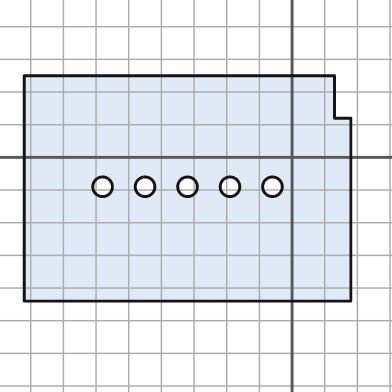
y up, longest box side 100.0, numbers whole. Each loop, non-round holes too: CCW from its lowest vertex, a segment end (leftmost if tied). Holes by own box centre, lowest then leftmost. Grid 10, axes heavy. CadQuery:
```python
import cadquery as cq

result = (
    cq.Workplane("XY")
    .moveTo(-82.0, -44.0)
    .lineTo(18.0, -44.0)
    .lineTo(18.0, 12.0)
    .lineTo(13.0, 12.0)
    .lineTo(13.0, 25.0)
    .lineTo(-82.0, 25.0)
    .close()
    .moveTo(-58.0, -9.0)
    .circle(3.0)
    .moveTo(-45.0, -9.0)
    .circle(3.0)
    .moveTo(-32.0, -9.0)
    .circle(3.0)
    .moveTo(-19.0, -9.0)
    .circle(3.0)
    .moveTo(-6.0, -9.0)
    .circle(3.0)
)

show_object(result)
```